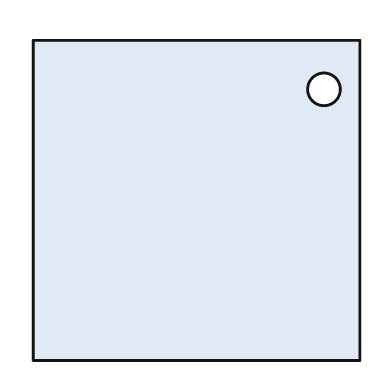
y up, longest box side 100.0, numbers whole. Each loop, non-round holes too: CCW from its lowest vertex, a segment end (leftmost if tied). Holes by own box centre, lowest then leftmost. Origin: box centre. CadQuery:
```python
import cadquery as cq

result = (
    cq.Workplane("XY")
    .moveTo(-50.0, -49.0)
    .lineTo(50.0, -49.0)
    .lineTo(50.0, 49.0)
    .lineTo(-50.0, 49.0)
    .close()
    .moveTo(39.0, 34.0)
    .circle(5.0)
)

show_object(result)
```